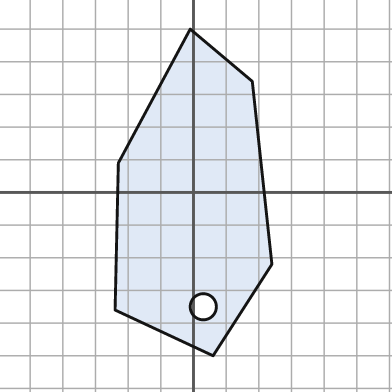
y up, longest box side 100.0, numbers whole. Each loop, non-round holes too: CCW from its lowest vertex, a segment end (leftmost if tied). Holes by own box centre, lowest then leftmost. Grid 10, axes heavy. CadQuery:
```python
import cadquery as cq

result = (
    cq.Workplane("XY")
    .moveTo(6.0, -50.0)
    .lineTo(24.0, -22.0)
    .lineTo(18.0, 34.0)
    .lineTo(-1.0, 50.0)
    .lineTo(-23.0, 9.0)
    .lineTo(-24.0, -36.0)
    .close()
    .moveTo(3.0, -35.0)
    .circle(4.0)
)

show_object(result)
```